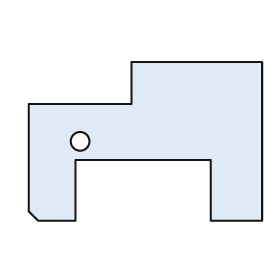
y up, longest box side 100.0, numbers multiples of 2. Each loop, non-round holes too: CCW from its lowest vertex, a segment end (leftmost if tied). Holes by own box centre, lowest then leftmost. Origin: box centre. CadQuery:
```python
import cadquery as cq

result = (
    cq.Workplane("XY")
    .moveTo(-46.0, -34.0)
    .lineTo(-30.0, -34.0)
    .lineTo(-30.0, -8.0)
    .lineTo(28.0, -8.0)
    .lineTo(28.0, -34.0)
    .lineTo(50.0, -34.0)
    .lineTo(50.0, 34.0)
    .lineTo(-6.0, 34.0)
    .lineTo(-6.0, 16.0)
    .lineTo(-50.0, 16.0)
    .lineTo(-50.0, -30.0)
    .close()
    .moveTo(-28.0, 0.0)
    .circle(4.0)
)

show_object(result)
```